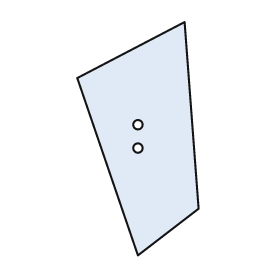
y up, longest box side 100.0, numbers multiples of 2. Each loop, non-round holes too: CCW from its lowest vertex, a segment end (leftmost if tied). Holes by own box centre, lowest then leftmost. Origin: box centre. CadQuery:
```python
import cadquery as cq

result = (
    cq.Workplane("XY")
    .moveTo(0.0, -50.0)
    .lineTo(26.0, -30.0)
    .lineTo(20.0, 50.0)
    .lineTo(-26.0, 26.0)
    .close()
    .moveTo(0.0, -4.0)
    .circle(2.0)
    .moveTo(0.0, 6.0)
    .circle(2.0)
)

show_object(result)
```